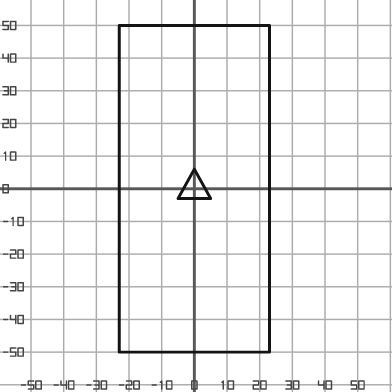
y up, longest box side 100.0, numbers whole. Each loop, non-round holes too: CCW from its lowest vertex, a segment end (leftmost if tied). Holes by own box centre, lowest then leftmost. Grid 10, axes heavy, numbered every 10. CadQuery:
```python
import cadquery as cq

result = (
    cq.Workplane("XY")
    .moveTo(-23.0, -50.0)
    .lineTo(23.0, -50.0)
    .lineTo(23.0, 50.0)
    .lineTo(-23.0, 50.0)
    .close()
    .moveTo(-5.0, -3.0)
    .lineTo(5.0, -3.0)
    .lineTo(0.0, 6.0)
    .close()
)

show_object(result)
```